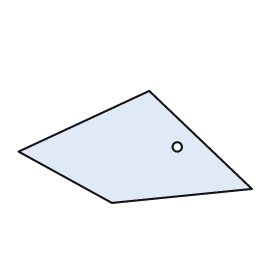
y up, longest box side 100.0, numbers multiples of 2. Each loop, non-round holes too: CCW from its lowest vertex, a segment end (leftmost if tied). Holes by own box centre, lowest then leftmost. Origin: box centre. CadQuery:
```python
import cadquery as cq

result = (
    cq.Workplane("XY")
    .moveTo(-10.0, -24.0)
    .lineTo(50.0, -18.0)
    .lineTo(6.0, 24.0)
    .lineTo(-50.0, -2.0)
    .close()
    .moveTo(18.0, 0.0)
    .circle(2.0)
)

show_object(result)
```